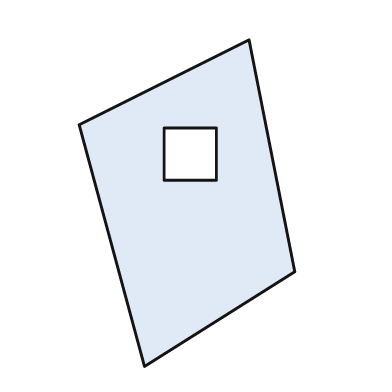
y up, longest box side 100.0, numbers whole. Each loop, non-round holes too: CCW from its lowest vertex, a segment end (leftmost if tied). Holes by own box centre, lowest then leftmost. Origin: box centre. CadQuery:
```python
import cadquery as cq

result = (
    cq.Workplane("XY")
    .moveTo(-13.0, -50.0)
    .lineTo(33.0, -21.0)
    .lineTo(19.0, 50.0)
    .lineTo(-33.0, 24.0)
    .close()
    .moveTo(-7.0, 7.0)
    .lineTo(9.0, 7.0)
    .lineTo(9.0, 23.0)
    .lineTo(-7.0, 23.0)
    .close()
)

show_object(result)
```